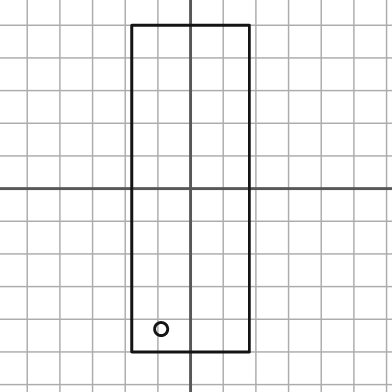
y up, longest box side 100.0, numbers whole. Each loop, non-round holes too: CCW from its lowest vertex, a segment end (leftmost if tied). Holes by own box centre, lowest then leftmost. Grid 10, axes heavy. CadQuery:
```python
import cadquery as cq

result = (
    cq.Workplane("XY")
    .moveTo(-18.0, -50.0)
    .lineTo(18.0, -50.0)
    .lineTo(18.0, 50.0)
    .lineTo(-18.0, 50.0)
    .close()
    .moveTo(-9.0, -43.0)
    .circle(2.0)
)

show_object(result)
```